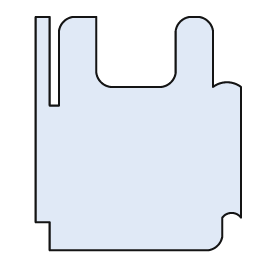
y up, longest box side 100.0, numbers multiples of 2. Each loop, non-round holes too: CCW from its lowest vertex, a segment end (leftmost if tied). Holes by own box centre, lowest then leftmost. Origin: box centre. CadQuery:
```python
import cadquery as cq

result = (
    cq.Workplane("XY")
    .moveTo(-38.0, -50.0)
    .lineTo(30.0, -50.0)
    .threePointArc((34.0, -48.0), (36.0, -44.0))
    .lineTo(36.0, -36.0)
    .threePointArc((40.0, -34.0), (44.0, -36.0))
    .lineTo(44.0, 20.0)
    .threePointArc((38.0, 22.0), (32.0, 20.0))
    .lineTo(32.0, 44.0)
    .threePointArc((30.0, 48.0), (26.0, 50.0))
    .lineTo(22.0, 50.0)
    .threePointArc((18.0, 48.0), (16.0, 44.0))
    .lineTo(16.0, 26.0)
    .threePointArc((14.0, 22.0), (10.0, 20.0))
    .lineTo(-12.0, 20.0)
    .threePointArc((-16.0, 22.0), (-18.0, 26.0))
    .lineTo(-18.0, 50.0)
    .lineTo(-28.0, 50.0)
    .threePointArc((-32.0, 48.0), (-34.0, 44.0))
    .lineTo(-34.0, 12.0)
    .lineTo(-38.0, 12.0)
    .lineTo(-38.0, 50.0)
    .lineTo(-44.0, 50.0)
    .lineTo(-44.0, -38.0)
    .lineTo(-38.0, -38.0)
    .close()
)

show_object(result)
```